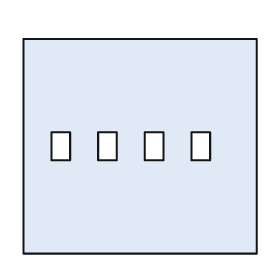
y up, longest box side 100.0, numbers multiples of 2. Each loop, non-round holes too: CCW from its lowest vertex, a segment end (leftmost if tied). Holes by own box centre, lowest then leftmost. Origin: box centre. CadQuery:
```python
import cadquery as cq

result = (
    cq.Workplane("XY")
    .moveTo(-50.0, -46.0)
    .lineTo(50.0, -46.0)
    .lineTo(50.0, 46.0)
    .lineTo(-50.0, 46.0)
    .close()
    .moveTo(-38.0, -6.0)
    .lineTo(-30.0, -6.0)
    .lineTo(-30.0, 6.0)
    .lineTo(-38.0, 6.0)
    .close()
    .moveTo(-18.0, -6.0)
    .lineTo(-10.0, -6.0)
    .lineTo(-10.0, 6.0)
    .lineTo(-18.0, 6.0)
    .close()
    .moveTo(2.0, -6.0)
    .lineTo(10.0, -6.0)
    .lineTo(10.0, 6.0)
    .lineTo(2.0, 6.0)
    .close()
    .moveTo(22.0, -6.0)
    .lineTo(30.0, -6.0)
    .lineTo(30.0, 6.0)
    .lineTo(22.0, 6.0)
    .close()
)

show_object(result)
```